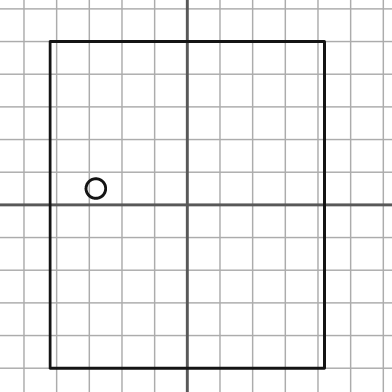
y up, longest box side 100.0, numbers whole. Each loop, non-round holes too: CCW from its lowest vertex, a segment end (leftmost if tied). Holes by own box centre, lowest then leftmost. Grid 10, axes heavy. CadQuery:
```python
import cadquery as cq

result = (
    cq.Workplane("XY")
    .moveTo(-42.0, -50.0)
    .lineTo(42.0, -50.0)
    .lineTo(42.0, 50.0)
    .lineTo(-42.0, 50.0)
    .close()
    .moveTo(-28.0, 5.0)
    .circle(3.0)
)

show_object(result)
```